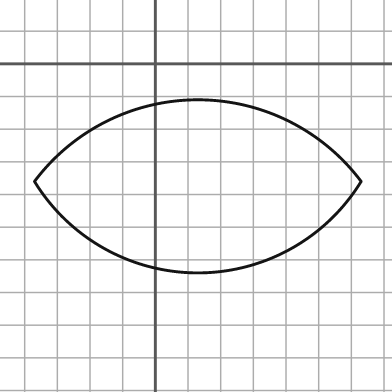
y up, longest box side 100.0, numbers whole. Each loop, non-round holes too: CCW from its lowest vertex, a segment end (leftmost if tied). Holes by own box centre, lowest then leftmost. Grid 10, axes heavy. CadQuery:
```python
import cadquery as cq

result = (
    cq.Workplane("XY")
    .moveTo(-37.0, -36.0)
    .threePointArc((13.0, -64.0), (63.0, -36.0))
    .threePointArc((13.0, -11.0), (-37.0, -36.0))
    .close()
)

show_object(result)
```